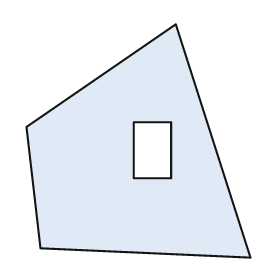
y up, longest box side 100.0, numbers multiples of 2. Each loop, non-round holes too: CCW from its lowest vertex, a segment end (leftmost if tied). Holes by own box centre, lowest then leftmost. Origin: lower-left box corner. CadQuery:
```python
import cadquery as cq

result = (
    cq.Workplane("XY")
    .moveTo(96.0, 0.0)
    .lineTo(64.0, 100.0)
    .lineTo(0.0, 56.0)
    .lineTo(6.0, 4.0)
    .close()
    .moveTo(46.0, 34.0)
    .lineTo(62.0, 34.0)
    .lineTo(62.0, 58.0)
    .lineTo(46.0, 58.0)
    .close()
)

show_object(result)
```